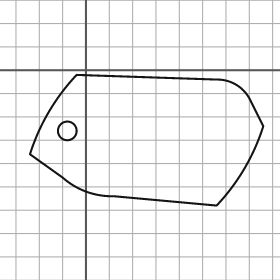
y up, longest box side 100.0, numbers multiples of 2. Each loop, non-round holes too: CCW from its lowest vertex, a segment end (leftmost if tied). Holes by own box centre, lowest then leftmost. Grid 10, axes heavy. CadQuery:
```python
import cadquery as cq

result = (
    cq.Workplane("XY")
    .moveTo(56.0, -58.0)
    .threePointArc((68.0, -42.0), (76.0, -24.0))
    .lineTo(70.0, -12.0)
    .threePointArc((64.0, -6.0), (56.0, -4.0))
    .lineTo(-4.0, -2.0)
    .threePointArc((-16.0, -18.0), (-24.0, -36.0))
    .lineTo(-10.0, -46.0)
    .threePointArc((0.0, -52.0), (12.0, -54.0))
    .close()
    .moveTo(-8.0, -26.0)
    .circle(4.0)
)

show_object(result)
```